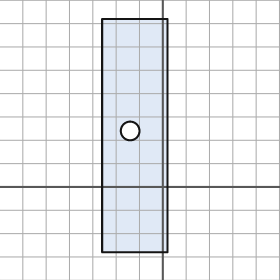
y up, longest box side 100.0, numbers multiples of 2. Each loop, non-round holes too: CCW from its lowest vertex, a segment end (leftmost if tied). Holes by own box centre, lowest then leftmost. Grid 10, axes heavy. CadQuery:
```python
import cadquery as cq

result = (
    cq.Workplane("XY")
    .moveTo(-26.0, -28.0)
    .lineTo(2.0, -28.0)
    .lineTo(2.0, 72.0)
    .lineTo(-26.0, 72.0)
    .close()
    .moveTo(-14.0, 24.0)
    .circle(4.0)
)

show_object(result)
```